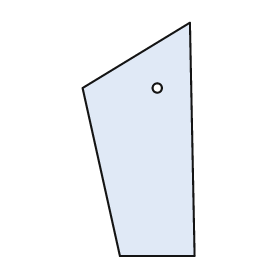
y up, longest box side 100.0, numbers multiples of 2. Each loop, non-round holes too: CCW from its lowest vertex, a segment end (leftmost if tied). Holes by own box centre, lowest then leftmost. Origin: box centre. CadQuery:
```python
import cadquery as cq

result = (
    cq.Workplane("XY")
    .moveTo(-8.0, -50.0)
    .lineTo(24.0, -50.0)
    .lineTo(22.0, 50.0)
    .lineTo(-24.0, 22.0)
    .close()
    .moveTo(8.0, 22.0)
    .circle(2.0)
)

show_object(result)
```